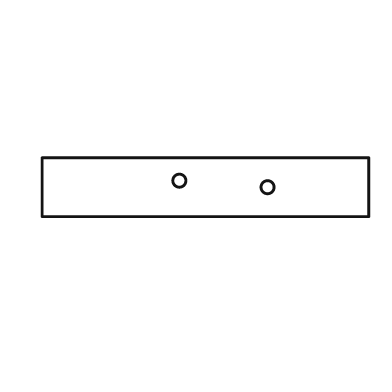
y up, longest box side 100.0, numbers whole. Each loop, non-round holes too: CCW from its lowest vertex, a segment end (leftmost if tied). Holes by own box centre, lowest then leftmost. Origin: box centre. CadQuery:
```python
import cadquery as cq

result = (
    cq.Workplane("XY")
    .moveTo(-50.0, -9.0)
    .lineTo(50.0, -9.0)
    .lineTo(50.0, 9.0)
    .lineTo(-50.0, 9.0)
    .close()
    .moveTo(19.0, 0.0)
    .circle(2.0)
    .moveTo(-8.0, 2.0)
    .circle(2.0)
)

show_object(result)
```